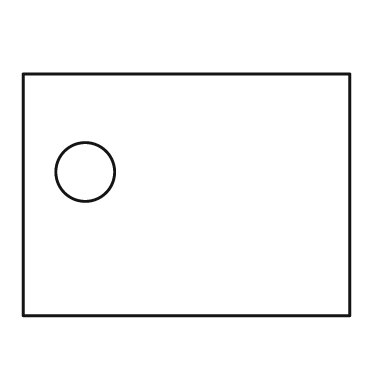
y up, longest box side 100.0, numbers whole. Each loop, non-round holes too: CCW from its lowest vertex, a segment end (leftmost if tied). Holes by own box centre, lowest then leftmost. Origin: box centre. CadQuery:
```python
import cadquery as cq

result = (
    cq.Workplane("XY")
    .moveTo(-50.0, -37.0)
    .lineTo(50.0, -37.0)
    .lineTo(50.0, 37.0)
    .lineTo(-50.0, 37.0)
    .close()
    .moveTo(-31.0, 7.0)
    .circle(9.0)
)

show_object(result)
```